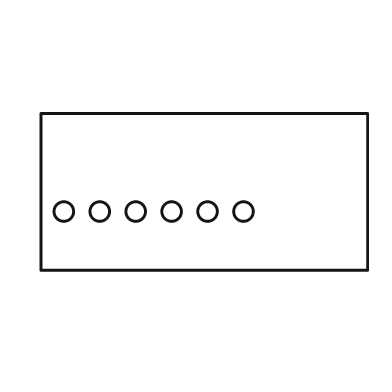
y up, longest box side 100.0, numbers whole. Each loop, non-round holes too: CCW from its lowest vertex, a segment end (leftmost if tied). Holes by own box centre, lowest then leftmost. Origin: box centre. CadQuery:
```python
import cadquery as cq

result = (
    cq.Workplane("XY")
    .moveTo(-50.0, -24.0)
    .lineTo(50.0, -24.0)
    .lineTo(50.0, 24.0)
    .lineTo(-50.0, 24.0)
    .close()
    .moveTo(-43.0, -6.0)
    .circle(3.0)
    .moveTo(-32.0, -6.0)
    .circle(3.0)
    .moveTo(-21.0, -6.0)
    .circle(3.0)
    .moveTo(-10.0, -6.0)
    .circle(3.0)
    .moveTo(1.0, -6.0)
    .circle(3.0)
    .moveTo(12.0, -6.0)
    .circle(3.0)
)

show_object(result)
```